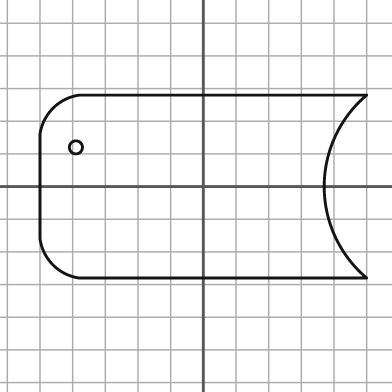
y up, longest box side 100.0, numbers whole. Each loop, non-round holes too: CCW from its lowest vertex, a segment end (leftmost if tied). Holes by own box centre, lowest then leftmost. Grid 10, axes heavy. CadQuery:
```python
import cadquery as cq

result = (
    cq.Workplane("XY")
    .moveTo(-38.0, -28.0)
    .lineTo(50.0, -28.0)
    .threePointArc((37.0, 0.0), (50.0, 28.0))
    .lineTo(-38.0, 28.0)
    .threePointArc((-46.0, 24.0), (-50.0, 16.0))
    .lineTo(-50.0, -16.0)
    .threePointArc((-46.0, -24.0), (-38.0, -28.0))
    .close()
    .moveTo(-39.0, 12.0)
    .circle(2.0)
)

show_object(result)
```